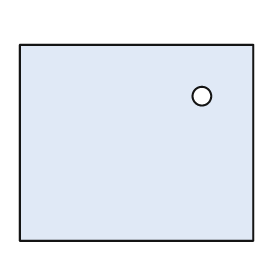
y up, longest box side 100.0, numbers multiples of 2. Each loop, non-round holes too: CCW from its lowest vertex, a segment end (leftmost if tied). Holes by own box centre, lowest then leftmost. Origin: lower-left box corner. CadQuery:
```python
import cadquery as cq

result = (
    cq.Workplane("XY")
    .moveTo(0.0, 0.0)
    .lineTo(100.0, 0.0)
    .lineTo(100.0, 84.0)
    .lineTo(0.0, 84.0)
    .close()
    .moveTo(78.0, 62.0)
    .circle(4.0)
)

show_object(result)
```